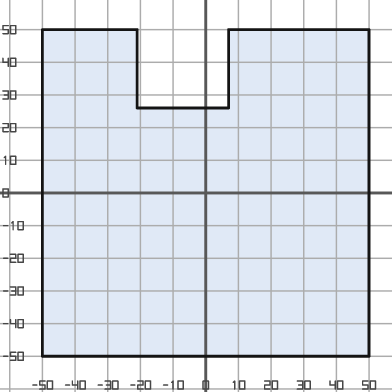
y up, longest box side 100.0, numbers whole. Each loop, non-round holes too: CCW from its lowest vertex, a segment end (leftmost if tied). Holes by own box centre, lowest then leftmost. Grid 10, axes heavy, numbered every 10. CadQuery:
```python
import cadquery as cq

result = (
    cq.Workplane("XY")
    .moveTo(-50.0, -50.0)
    .lineTo(50.0, -50.0)
    .lineTo(50.0, 50.0)
    .lineTo(7.0, 50.0)
    .lineTo(7.0, 26.0)
    .lineTo(-21.0, 26.0)
    .lineTo(-21.0, 50.0)
    .lineTo(-50.0, 50.0)
    .close()
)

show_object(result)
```